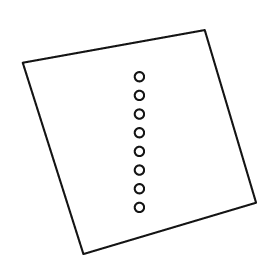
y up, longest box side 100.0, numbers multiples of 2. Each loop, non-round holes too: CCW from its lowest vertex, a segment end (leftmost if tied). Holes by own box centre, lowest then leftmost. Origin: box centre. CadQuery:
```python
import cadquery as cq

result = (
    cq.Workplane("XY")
    .moveTo(-24.0, -48.0)
    .lineTo(50.0, -26.0)
    .lineTo(28.0, 48.0)
    .lineTo(-50.0, 34.0)
    .close()
    .moveTo(0.0, -28.0)
    .circle(2.0)
    .moveTo(0.0, -20.0)
    .circle(2.0)
    .moveTo(0.0, -12.0)
    .circle(2.0)
    .moveTo(0.0, -4.0)
    .circle(2.0)
    .moveTo(0.0, 4.0)
    .circle(2.0)
    .moveTo(0.0, 12.0)
    .circle(2.0)
    .moveTo(0.0, 20.0)
    .circle(2.0)
    .moveTo(0.0, 28.0)
    .circle(2.0)
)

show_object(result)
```